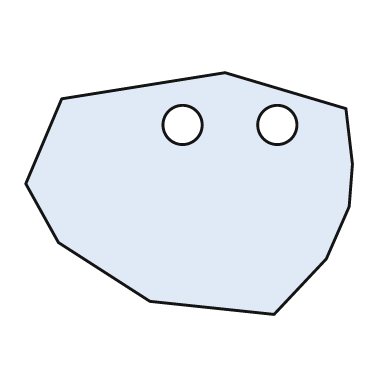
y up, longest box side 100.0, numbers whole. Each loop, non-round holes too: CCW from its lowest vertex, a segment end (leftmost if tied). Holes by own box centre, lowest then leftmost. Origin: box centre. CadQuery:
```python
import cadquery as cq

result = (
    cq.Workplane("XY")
    .moveTo(26.0, -37.0)
    .lineTo(42.0, -20.0)
    .lineTo(49.0, -4.0)
    .lineTo(50.0, 9.0)
    .lineTo(48.0, 26.0)
    .lineTo(11.0, 37.0)
    .lineTo(-39.0, 29.0)
    .lineTo(-50.0, 3.0)
    .lineTo(-40.0, -15.0)
    .lineTo(-12.0, -33.0)
    .close()
    .moveTo(-2.0, 21.0)
    .circle(6.0)
    .moveTo(27.0, 21.0)
    .circle(6.0)
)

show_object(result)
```